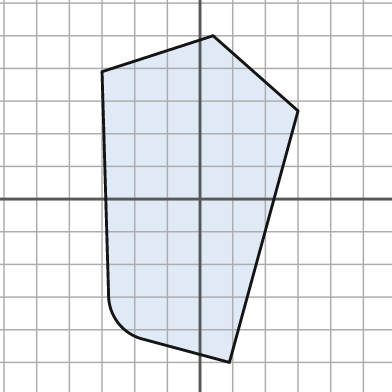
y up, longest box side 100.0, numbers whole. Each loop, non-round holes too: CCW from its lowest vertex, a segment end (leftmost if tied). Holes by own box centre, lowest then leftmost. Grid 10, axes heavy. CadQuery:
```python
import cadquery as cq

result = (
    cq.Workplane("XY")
    .moveTo(9.0, -50.0)
    .lineTo(30.0, 27.0)
    .lineTo(4.0, 50.0)
    .lineTo(-30.0, 39.0)
    .lineTo(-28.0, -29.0)
    .threePointArc((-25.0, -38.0), (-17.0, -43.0))
    .close()
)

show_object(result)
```